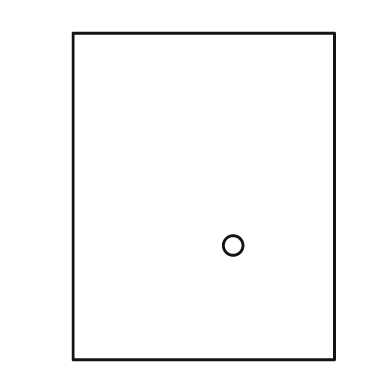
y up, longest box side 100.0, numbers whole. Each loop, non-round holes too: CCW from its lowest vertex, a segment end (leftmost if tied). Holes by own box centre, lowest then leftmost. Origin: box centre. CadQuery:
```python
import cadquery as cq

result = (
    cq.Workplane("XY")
    .moveTo(-40.0, -50.0)
    .lineTo(40.0, -50.0)
    .lineTo(40.0, 50.0)
    .lineTo(-40.0, 50.0)
    .close()
    .moveTo(9.0, -15.0)
    .circle(3.0)
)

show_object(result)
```